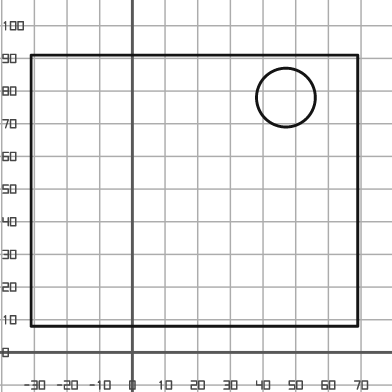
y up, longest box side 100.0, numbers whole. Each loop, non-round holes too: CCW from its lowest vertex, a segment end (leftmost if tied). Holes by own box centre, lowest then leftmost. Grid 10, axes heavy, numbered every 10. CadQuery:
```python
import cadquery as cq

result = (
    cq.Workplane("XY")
    .moveTo(-31.0, 8.0)
    .lineTo(69.0, 8.0)
    .lineTo(69.0, 91.0)
    .lineTo(-31.0, 91.0)
    .close()
    .moveTo(47.0, 78.0)
    .circle(9.0)
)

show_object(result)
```